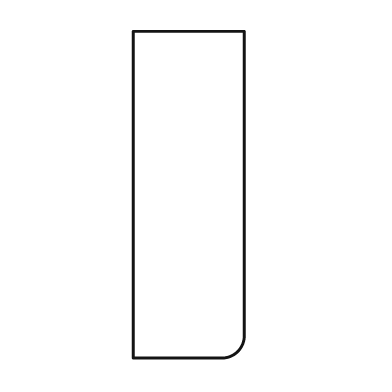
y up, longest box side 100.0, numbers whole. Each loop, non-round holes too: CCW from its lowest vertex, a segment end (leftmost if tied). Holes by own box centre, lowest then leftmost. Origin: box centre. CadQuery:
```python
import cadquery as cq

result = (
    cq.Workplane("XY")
    .moveTo(-17.0, -50.0)
    .lineTo(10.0, -50.0)
    .threePointArc((15.0, -48.0), (17.0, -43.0))
    .lineTo(17.0, 50.0)
    .lineTo(-17.0, 50.0)
    .close()
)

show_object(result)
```